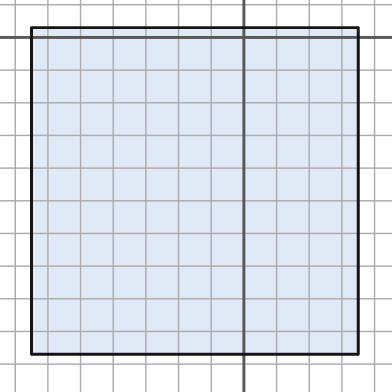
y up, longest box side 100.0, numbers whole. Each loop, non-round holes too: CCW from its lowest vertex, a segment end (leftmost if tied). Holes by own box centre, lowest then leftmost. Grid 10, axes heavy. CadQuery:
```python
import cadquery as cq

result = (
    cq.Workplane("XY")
    .moveTo(-65.0, -97.0)
    .lineTo(35.0, -97.0)
    .lineTo(35.0, 3.0)
    .lineTo(-65.0, 3.0)
    .close()
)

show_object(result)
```